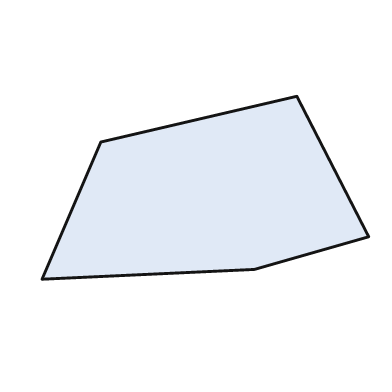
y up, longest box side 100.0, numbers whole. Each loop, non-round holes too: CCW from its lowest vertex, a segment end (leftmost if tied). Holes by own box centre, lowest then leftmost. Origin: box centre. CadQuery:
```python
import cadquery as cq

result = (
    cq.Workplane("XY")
    .moveTo(-50.0, -28.0)
    .lineTo(15.0, -25.0)
    .lineTo(50.0, -15.0)
    .lineTo(28.0, 28.0)
    .lineTo(-32.0, 14.0)
    .close()
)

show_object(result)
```